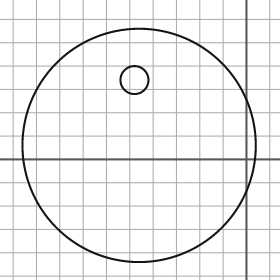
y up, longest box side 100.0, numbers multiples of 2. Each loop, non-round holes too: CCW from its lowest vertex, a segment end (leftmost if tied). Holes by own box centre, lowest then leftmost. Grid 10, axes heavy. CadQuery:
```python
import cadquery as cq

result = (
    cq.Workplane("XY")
    .moveTo(-46.0, 6.0)
    .circle(50.0)
    .moveTo(-48.0, 34.0)
    .circle(6.0)
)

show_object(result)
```